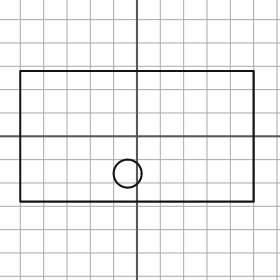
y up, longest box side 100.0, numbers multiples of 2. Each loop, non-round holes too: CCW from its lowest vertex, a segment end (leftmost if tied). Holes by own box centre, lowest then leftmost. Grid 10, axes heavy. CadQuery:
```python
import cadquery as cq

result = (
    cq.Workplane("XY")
    .moveTo(-50.0, -28.0)
    .lineTo(50.0, -28.0)
    .lineTo(50.0, 28.0)
    .lineTo(-50.0, 28.0)
    .close()
    .moveTo(-4.0, -16.0)
    .circle(6.0)
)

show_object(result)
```